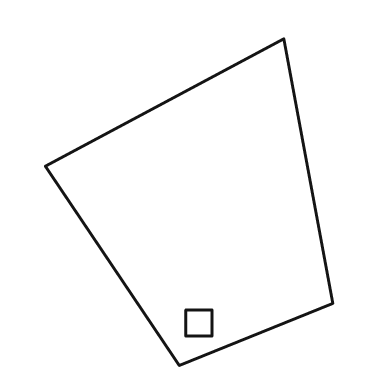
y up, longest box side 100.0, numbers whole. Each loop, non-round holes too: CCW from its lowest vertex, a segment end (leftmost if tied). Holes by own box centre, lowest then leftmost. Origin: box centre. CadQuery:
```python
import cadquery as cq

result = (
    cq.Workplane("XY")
    .moveTo(-3.0, -50.0)
    .lineTo(44.0, -31.0)
    .lineTo(29.0, 50.0)
    .lineTo(-44.0, 11.0)
    .close()
    .moveTo(-1.0, -41.0)
    .lineTo(7.0, -41.0)
    .lineTo(7.0, -33.0)
    .lineTo(-1.0, -33.0)
    .close()
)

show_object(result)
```